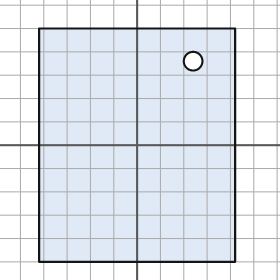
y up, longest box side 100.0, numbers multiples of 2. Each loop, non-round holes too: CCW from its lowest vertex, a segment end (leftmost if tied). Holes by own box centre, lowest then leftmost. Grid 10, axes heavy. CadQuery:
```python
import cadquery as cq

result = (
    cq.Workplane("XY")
    .moveTo(-42.0, -50.0)
    .lineTo(42.0, -50.0)
    .lineTo(42.0, 50.0)
    .lineTo(-42.0, 50.0)
    .close()
    .moveTo(24.0, 36.0)
    .circle(4.0)
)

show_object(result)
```